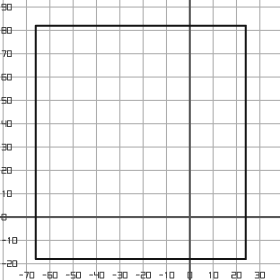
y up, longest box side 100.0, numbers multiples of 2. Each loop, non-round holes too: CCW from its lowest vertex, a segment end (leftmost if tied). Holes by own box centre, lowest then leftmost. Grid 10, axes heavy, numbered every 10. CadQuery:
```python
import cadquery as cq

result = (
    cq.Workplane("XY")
    .moveTo(-66.0, -18.0)
    .lineTo(24.0, -18.0)
    .lineTo(24.0, 82.0)
    .lineTo(-66.0, 82.0)
    .close()
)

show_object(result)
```